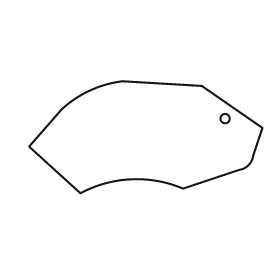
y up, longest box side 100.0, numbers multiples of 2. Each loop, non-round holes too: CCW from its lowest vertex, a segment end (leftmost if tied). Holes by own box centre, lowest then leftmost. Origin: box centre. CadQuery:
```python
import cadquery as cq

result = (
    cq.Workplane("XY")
    .moveTo(-28.0, -24.0)
    .threePointArc((-6.0, -18.0), (16.0, -22.0))
    .lineTo(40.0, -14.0)
    .threePointArc((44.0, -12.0), (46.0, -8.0))
    .lineTo(50.0, 4.0)
    .lineTo(24.0, 22.0)
    .lineTo(-10.0, 24.0)
    .threePointArc((-24.0, 20.0), (-36.0, 12.0))
    .lineTo(-50.0, -4.0)
    .close()
    .moveTo(34.0, 8.0)
    .circle(2.0)
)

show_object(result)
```